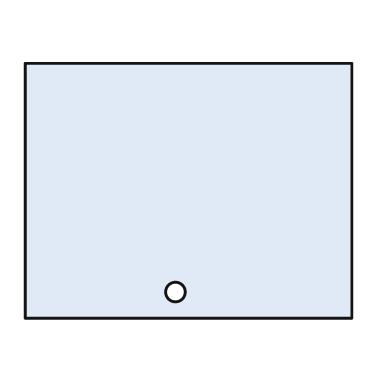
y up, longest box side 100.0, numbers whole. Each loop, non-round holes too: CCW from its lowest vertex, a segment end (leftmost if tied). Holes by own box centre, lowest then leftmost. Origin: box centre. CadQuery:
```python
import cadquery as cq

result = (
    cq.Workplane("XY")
    .moveTo(-50.0, -39.0)
    .lineTo(50.0, -39.0)
    .lineTo(50.0, 39.0)
    .lineTo(-50.0, 39.0)
    .close()
    .moveTo(-4.0, -31.0)
    .circle(3.0)
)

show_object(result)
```